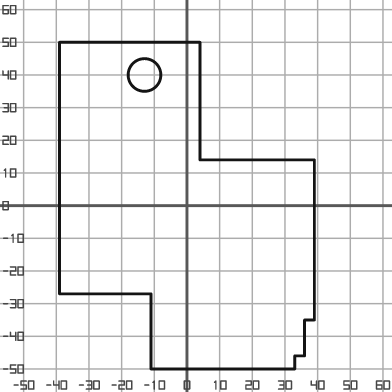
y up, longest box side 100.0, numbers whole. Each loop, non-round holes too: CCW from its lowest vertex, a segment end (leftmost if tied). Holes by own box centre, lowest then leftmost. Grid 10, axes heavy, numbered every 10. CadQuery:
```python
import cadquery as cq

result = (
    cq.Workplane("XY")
    .moveTo(-11.0, -50.0)
    .lineTo(33.0, -50.0)
    .lineTo(33.0, -46.0)
    .lineTo(36.0, -46.0)
    .lineTo(36.0, -35.0)
    .lineTo(39.0, -35.0)
    .lineTo(39.0, 14.0)
    .lineTo(4.0, 14.0)
    .lineTo(4.0, 50.0)
    .lineTo(-39.0, 50.0)
    .lineTo(-39.0, -27.0)
    .lineTo(-11.0, -27.0)
    .close()
    .moveTo(-13.0, 40.0)
    .circle(5.0)
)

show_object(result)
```